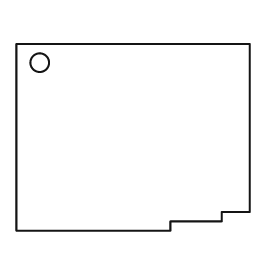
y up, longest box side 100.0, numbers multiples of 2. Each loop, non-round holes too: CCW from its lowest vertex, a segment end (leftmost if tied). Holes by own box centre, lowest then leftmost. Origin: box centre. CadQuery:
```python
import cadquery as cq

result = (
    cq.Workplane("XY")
    .moveTo(-50.0, -40.0)
    .lineTo(16.0, -40.0)
    .lineTo(16.0, -36.0)
    .lineTo(38.0, -36.0)
    .lineTo(38.0, -32.0)
    .lineTo(50.0, -32.0)
    .lineTo(50.0, 40.0)
    .lineTo(-50.0, 40.0)
    .close()
    .moveTo(-40.0, 32.0)
    .circle(4.0)
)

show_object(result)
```